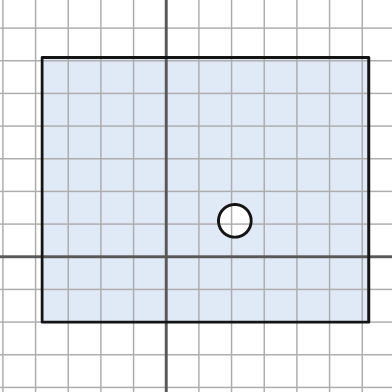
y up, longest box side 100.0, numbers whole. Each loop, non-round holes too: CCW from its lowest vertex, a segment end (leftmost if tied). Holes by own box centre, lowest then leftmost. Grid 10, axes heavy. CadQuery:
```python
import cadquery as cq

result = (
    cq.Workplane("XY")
    .moveTo(-38.0, -20.0)
    .lineTo(62.0, -20.0)
    .lineTo(62.0, 61.0)
    .lineTo(-38.0, 61.0)
    .close()
    .moveTo(21.0, 11.0)
    .circle(5.0)
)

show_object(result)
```